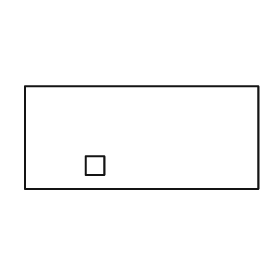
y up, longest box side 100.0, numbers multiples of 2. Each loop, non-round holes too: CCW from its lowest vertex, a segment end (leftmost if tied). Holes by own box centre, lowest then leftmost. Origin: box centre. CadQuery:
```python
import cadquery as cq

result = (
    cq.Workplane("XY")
    .moveTo(-50.0, -22.0)
    .lineTo(50.0, -22.0)
    .lineTo(50.0, 22.0)
    .lineTo(-50.0, 22.0)
    .close()
    .moveTo(-24.0, -16.0)
    .lineTo(-16.0, -16.0)
    .lineTo(-16.0, -8.0)
    .lineTo(-24.0, -8.0)
    .close()
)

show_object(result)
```